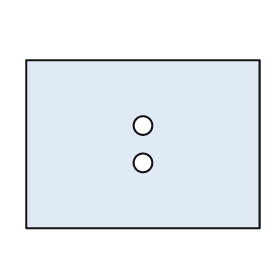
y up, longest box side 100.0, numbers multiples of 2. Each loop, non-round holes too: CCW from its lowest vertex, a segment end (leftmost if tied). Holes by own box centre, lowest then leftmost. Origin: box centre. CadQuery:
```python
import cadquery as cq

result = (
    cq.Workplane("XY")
    .moveTo(-50.0, -36.0)
    .lineTo(50.0, -36.0)
    .lineTo(50.0, 36.0)
    .lineTo(-50.0, 36.0)
    .close()
    .moveTo(0.0, -8.0)
    .circle(4.0)
    .moveTo(0.0, 8.0)
    .circle(4.0)
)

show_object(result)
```